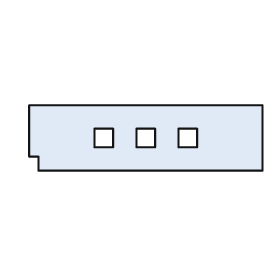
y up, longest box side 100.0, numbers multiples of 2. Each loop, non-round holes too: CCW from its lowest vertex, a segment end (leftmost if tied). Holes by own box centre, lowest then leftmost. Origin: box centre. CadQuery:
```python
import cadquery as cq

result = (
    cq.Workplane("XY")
    .moveTo(-46.0, -14.0)
    .lineTo(50.0, -14.0)
    .lineTo(50.0, 14.0)
    .lineTo(-50.0, 14.0)
    .lineTo(-50.0, -8.0)
    .lineTo(-46.0, -8.0)
    .close()
    .moveTo(-22.0, -4.0)
    .lineTo(-14.0, -4.0)
    .lineTo(-14.0, 4.0)
    .lineTo(-22.0, 4.0)
    .close()
    .moveTo(-4.0, -4.0)
    .lineTo(4.0, -4.0)
    .lineTo(4.0, 4.0)
    .lineTo(-4.0, 4.0)
    .close()
    .moveTo(14.0, -4.0)
    .lineTo(22.0, -4.0)
    .lineTo(22.0, 4.0)
    .lineTo(14.0, 4.0)
    .close()
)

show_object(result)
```